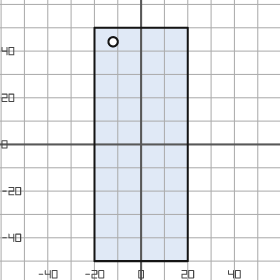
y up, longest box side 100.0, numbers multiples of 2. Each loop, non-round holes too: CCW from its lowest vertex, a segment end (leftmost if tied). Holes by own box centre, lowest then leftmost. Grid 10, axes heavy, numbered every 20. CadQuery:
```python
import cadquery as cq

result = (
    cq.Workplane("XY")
    .moveTo(-20.0, -50.0)
    .lineTo(20.0, -50.0)
    .lineTo(20.0, 50.0)
    .lineTo(-20.0, 50.0)
    .close()
    .moveTo(-12.0, 44.0)
    .circle(2.0)
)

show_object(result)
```